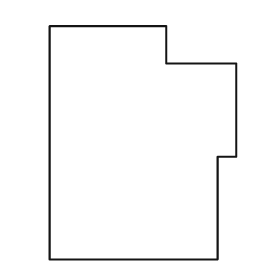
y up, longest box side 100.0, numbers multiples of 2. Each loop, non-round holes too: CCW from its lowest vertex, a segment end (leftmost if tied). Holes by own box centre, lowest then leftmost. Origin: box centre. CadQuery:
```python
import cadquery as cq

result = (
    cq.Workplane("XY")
    .moveTo(-40.0, -50.0)
    .lineTo(32.0, -50.0)
    .lineTo(32.0, -6.0)
    .lineTo(40.0, -6.0)
    .lineTo(40.0, 34.0)
    .lineTo(10.0, 34.0)
    .lineTo(10.0, 50.0)
    .lineTo(-40.0, 50.0)
    .close()
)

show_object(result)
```